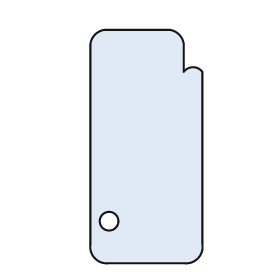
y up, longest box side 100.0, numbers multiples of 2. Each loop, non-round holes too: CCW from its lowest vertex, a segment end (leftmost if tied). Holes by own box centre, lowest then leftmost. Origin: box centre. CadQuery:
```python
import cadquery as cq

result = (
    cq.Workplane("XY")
    .moveTo(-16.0, -50.0)
    .lineTo(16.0, -50.0)
    .threePointArc((22.0, -48.0), (24.0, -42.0))
    .lineTo(24.0, 32.0)
    .threePointArc((20.0, 34.0), (16.0, 32.0))
    .lineTo(16.0, 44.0)
    .threePointArc((14.0, 48.0), (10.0, 50.0))
    .lineTo(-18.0, 50.0)
    .threePointArc((-22.0, 48.0), (-24.0, 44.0))
    .lineTo(-24.0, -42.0)
    .threePointArc((-22.0, -48.0), (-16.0, -50.0))
    .close()
    .moveTo(-16.0, -32.0)
    .circle(4.0)
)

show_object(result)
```